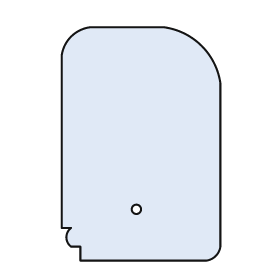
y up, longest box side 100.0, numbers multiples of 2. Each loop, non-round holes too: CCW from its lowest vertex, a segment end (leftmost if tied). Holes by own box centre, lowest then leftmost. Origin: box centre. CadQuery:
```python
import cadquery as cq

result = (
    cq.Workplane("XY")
    .moveTo(-26.0, -50.0)
    .lineTo(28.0, -50.0)
    .threePointArc((32.0, -48.0), (34.0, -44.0))
    .lineTo(34.0, 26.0)
    .threePointArc((26.0, 42.0), (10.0, 50.0))
    .lineTo(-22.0, 50.0)
    .threePointArc((-30.0, 46.0), (-34.0, 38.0))
    .lineTo(-34.0, -36.0)
    .lineTo(-30.0, -36.0)
    .threePointArc((-32.0, -40.0), (-30.0, -44.0))
    .lineTo(-26.0, -44.0)
    .close()
    .moveTo(-2.0, -28.0)
    .circle(2.0)
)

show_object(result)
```